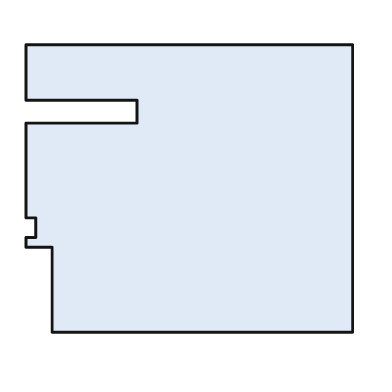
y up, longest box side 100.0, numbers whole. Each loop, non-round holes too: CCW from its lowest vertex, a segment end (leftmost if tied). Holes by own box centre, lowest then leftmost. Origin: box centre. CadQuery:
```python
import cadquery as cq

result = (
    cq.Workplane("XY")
    .moveTo(-42.0, -44.0)
    .lineTo(50.0, -44.0)
    .lineTo(50.0, 44.0)
    .lineTo(-50.0, 44.0)
    .lineTo(-50.0, 27.0)
    .lineTo(-16.0, 27.0)
    .lineTo(-16.0, 20.0)
    .lineTo(-50.0, 20.0)
    .lineTo(-50.0, -9.0)
    .lineTo(-47.0, -9.0)
    .lineTo(-47.0, -15.0)
    .lineTo(-50.0, -15.0)
    .lineTo(-50.0, -18.0)
    .lineTo(-42.0, -18.0)
    .close()
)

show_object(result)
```